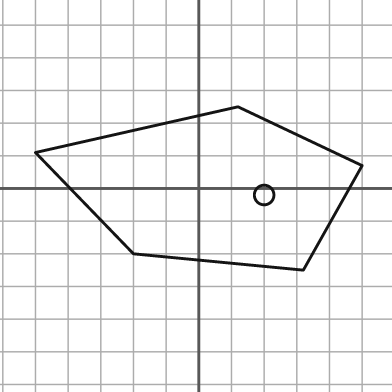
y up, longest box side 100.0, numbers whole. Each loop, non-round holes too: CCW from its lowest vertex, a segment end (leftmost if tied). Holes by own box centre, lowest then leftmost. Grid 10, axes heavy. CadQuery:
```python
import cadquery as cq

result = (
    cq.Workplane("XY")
    .moveTo(32.0, -25.0)
    .lineTo(50.0, 7.0)
    .lineTo(12.0, 25.0)
    .lineTo(-50.0, 11.0)
    .lineTo(-20.0, -20.0)
    .close()
    .moveTo(20.0, -2.0)
    .circle(3.0)
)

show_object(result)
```